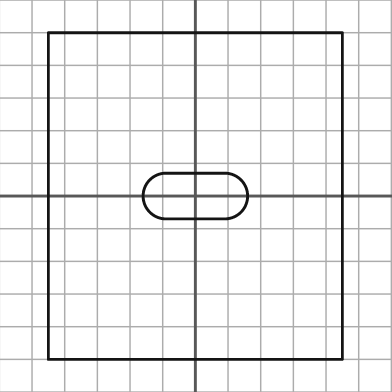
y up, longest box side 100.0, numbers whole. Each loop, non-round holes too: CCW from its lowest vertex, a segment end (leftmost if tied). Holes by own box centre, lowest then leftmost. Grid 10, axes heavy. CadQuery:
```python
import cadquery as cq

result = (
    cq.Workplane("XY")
    .moveTo(-45.0, -50.0)
    .lineTo(45.0, -50.0)
    .lineTo(45.0, 50.0)
    .lineTo(-45.0, 50.0)
    .close()
    .moveTo(-9.0, -7.0)
    .lineTo(9.0, -7.0)
    .threePointArc((16.0, 0.0), (9.0, 7.0))
    .lineTo(-9.0, 7.0)
    .threePointArc((-16.0, 0.0), (-9.0, -7.0))
    .close()
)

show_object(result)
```